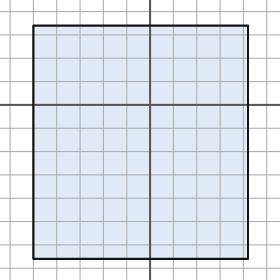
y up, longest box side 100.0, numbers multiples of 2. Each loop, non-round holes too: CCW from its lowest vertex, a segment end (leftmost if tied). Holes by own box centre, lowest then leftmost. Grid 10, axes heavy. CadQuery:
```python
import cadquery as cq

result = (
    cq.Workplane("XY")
    .moveTo(-50.0, -66.0)
    .lineTo(42.0, -66.0)
    .lineTo(42.0, 34.0)
    .lineTo(-50.0, 34.0)
    .close()
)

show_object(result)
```